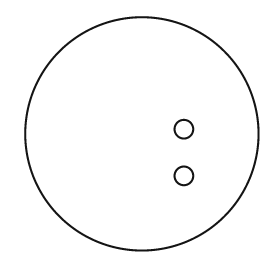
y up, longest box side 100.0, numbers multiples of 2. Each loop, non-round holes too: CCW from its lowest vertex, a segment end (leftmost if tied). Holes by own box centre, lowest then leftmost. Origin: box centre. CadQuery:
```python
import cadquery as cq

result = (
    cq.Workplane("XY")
    .moveTo(0.0, 0.0)
    .circle(50.0)
    .moveTo(18.0, -18.0)
    .circle(4.0)
    .moveTo(18.0, 2.0)
    .circle(4.0)
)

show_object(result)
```